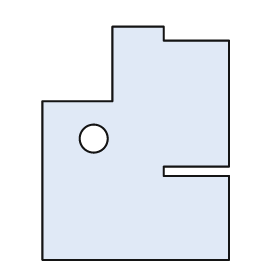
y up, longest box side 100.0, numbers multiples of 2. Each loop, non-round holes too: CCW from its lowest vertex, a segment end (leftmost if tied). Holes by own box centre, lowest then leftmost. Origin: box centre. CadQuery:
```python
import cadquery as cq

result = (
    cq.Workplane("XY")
    .moveTo(-40.0, -50.0)
    .lineTo(40.0, -50.0)
    .lineTo(40.0, -14.0)
    .lineTo(12.0, -14.0)
    .lineTo(12.0, -10.0)
    .lineTo(40.0, -10.0)
    .lineTo(40.0, 44.0)
    .lineTo(12.0, 44.0)
    .lineTo(12.0, 50.0)
    .lineTo(-10.0, 50.0)
    .lineTo(-10.0, 18.0)
    .lineTo(-40.0, 18.0)
    .close()
    .moveTo(-18.0, 2.0)
    .circle(6.0)
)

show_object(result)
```